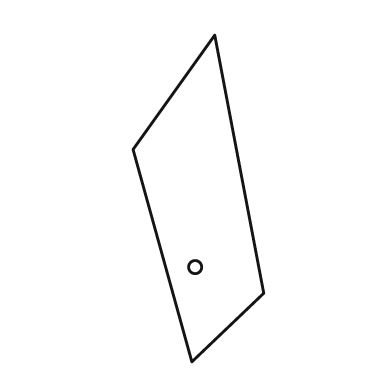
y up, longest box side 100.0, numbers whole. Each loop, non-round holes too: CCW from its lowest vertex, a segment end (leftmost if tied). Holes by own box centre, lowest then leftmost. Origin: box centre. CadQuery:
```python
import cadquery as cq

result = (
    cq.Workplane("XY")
    .moveTo(-2.0, -50.0)
    .lineTo(20.0, -29.0)
    .lineTo(5.0, 50.0)
    .lineTo(-20.0, 15.0)
    .close()
    .moveTo(-1.0, -21.0)
    .circle(2.0)
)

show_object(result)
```